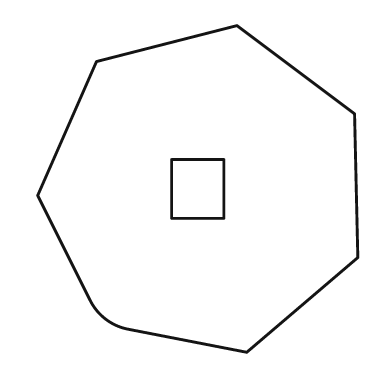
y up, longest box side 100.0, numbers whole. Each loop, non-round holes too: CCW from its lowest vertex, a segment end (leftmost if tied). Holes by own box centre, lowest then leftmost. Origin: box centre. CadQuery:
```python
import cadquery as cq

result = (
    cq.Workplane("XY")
    .moveTo(15.0, -50.0)
    .lineTo(49.0, -21.0)
    .lineTo(48.0, 23.0)
    .lineTo(12.0, 50.0)
    .lineTo(-31.0, 39.0)
    .lineTo(-49.0, -2.0)
    .lineTo(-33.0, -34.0)
    .threePointArc((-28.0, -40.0), (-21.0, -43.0))
    .close()
    .moveTo(-8.0, -9.0)
    .lineTo(8.0, -9.0)
    .lineTo(8.0, 9.0)
    .lineTo(-8.0, 9.0)
    .close()
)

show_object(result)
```